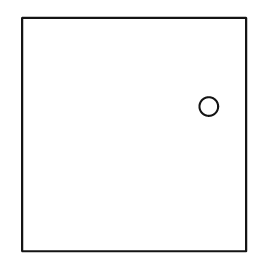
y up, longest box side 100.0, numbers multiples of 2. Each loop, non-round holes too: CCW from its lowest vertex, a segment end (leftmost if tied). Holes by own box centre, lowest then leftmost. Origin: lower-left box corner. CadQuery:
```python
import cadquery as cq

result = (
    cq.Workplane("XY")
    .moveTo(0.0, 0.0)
    .lineTo(96.0, 0.0)
    .lineTo(96.0, 100.0)
    .lineTo(0.0, 100.0)
    .close()
    .moveTo(80.0, 62.0)
    .circle(4.0)
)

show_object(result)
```